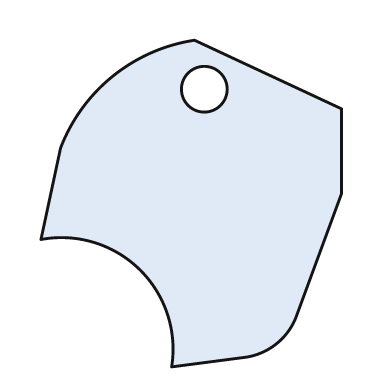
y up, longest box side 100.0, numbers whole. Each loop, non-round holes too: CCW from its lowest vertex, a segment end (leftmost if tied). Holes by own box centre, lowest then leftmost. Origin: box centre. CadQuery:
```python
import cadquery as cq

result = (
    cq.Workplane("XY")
    .moveTo(-6.0, -50.0)
    .lineTo(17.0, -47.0)
    .threePointArc((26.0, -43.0), (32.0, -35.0))
    .lineTo(46.0, 3.0)
    .lineTo(46.0, 29.0)
    .lineTo(1.0, 50.0)
    .threePointArc((-24.0, 39.0), (-40.0, 17.0))
    .lineTo(-46.0, -11.0)
    .threePointArc((-16.0, -20.0), (-6.0, -50.0))
    .close()
    .moveTo(4.0, 35.0)
    .circle(7.0)
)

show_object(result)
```